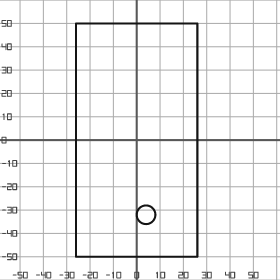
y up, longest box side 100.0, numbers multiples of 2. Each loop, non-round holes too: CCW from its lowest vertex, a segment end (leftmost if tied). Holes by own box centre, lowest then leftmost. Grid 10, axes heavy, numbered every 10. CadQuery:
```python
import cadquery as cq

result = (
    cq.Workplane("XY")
    .moveTo(-26.0, -50.0)
    .lineTo(26.0, -50.0)
    .lineTo(26.0, 50.0)
    .lineTo(-26.0, 50.0)
    .close()
    .moveTo(4.0, -32.0)
    .circle(4.0)
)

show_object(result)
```